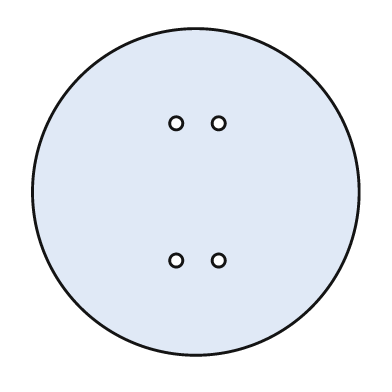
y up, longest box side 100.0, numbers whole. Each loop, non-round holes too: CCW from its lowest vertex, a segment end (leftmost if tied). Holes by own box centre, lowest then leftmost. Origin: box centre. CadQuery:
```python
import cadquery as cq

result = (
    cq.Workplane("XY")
    .moveTo(0.0, 0.0)
    .circle(50.0)
    .moveTo(-6.0, -21.0)
    .circle(2.0)
    .moveTo(7.0, -21.0)
    .circle(2.0)
    .moveTo(-6.0, 21.0)
    .circle(2.0)
    .moveTo(7.0, 21.0)
    .circle(2.0)
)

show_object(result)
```